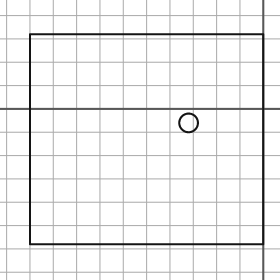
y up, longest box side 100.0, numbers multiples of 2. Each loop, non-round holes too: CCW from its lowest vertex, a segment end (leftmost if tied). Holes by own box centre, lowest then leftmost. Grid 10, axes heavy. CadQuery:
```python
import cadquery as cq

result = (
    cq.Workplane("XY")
    .moveTo(-100.0, -58.0)
    .lineTo(0.0, -58.0)
    .lineTo(0.0, 32.0)
    .lineTo(-100.0, 32.0)
    .close()
    .moveTo(-32.0, -6.0)
    .circle(4.0)
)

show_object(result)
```